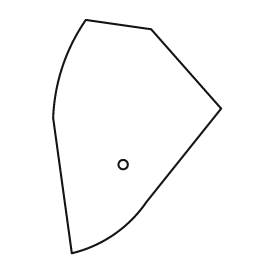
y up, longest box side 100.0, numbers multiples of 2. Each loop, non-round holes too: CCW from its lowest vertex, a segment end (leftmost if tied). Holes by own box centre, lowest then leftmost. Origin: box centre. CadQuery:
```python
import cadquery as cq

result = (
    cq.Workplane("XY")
    .moveTo(-28.0, -50.0)
    .threePointArc((-10.0, -42.0), (4.0, -28.0))
    .lineTo(36.0, 12.0)
    .lineTo(6.0, 46.0)
    .lineTo(-22.0, 50.0)
    .threePointArc((-32.0, 30.0), (-36.0, 8.0))
    .close()
    .moveTo(-6.0, -12.0)
    .circle(2.0)
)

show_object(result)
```